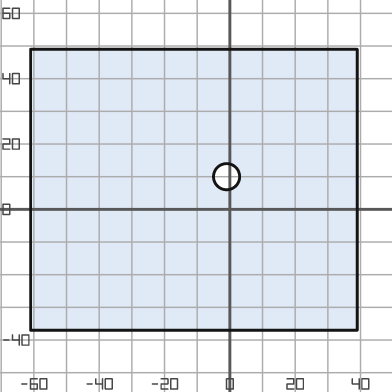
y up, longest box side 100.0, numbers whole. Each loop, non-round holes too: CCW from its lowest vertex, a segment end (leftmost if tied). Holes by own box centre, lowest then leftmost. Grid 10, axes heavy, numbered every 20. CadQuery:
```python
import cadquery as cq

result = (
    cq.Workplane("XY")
    .moveTo(-61.0, -37.0)
    .lineTo(39.0, -37.0)
    .lineTo(39.0, 49.0)
    .lineTo(-61.0, 49.0)
    .close()
    .moveTo(-1.0, 10.0)
    .circle(4.0)
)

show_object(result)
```